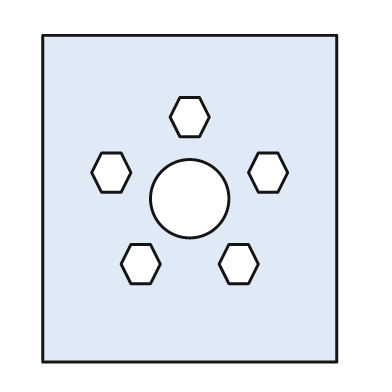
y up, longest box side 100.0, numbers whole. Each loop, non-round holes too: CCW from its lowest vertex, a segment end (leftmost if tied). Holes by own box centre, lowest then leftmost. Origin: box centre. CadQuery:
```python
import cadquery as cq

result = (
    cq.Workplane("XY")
    .moveTo(-45.0, -50.0)
    .lineTo(45.0, -50.0)
    .lineTo(45.0, 50.0)
    .lineTo(-45.0, 50.0)
    .close()
    .moveTo(-18.0, -26.0)
    .lineTo(-12.0, -26.0)
    .lineTo(-9.0, -20.0)
    .lineTo(-12.0, -14.0)
    .lineTo(-18.0, -14.0)
    .lineTo(-21.0, -20.0)
    .close()
    .moveTo(12.0, -26.0)
    .lineTo(18.0, -26.0)
    .lineTo(21.0, -20.0)
    .lineTo(18.0, -14.0)
    .lineTo(12.0, -14.0)
    .lineTo(9.0, -20.0)
    .close()
    .moveTo(0.0, 0.0)
    .circle(12.0)
    .moveTo(-27.0, 2.0)
    .lineTo(-21.0, 2.0)
    .lineTo(-18.0, 8.0)
    .lineTo(-21.0, 14.0)
    .lineTo(-27.0, 14.0)
    .lineTo(-30.0, 8.0)
    .close()
    .moveTo(21.0, 2.0)
    .lineTo(27.0, 2.0)
    .lineTo(30.0, 8.0)
    .lineTo(27.0, 14.0)
    .lineTo(21.0, 14.0)
    .lineTo(18.0, 8.0)
    .close()
    .moveTo(-3.0, 19.0)
    .lineTo(3.0, 19.0)
    .lineTo(6.0, 25.0)
    .lineTo(3.0, 31.0)
    .lineTo(-3.0, 31.0)
    .lineTo(-6.0, 25.0)
    .close()
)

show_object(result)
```